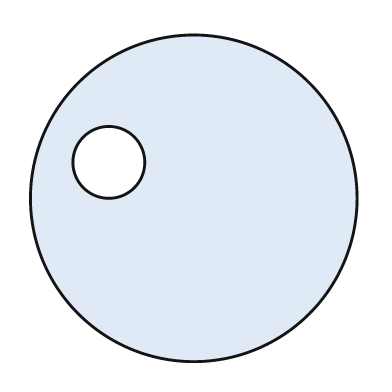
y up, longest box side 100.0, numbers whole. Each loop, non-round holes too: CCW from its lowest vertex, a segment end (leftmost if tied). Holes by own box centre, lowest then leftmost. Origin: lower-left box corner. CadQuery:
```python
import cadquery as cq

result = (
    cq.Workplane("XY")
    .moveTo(50.0, 50.0)
    .circle(50.0)
    .moveTo(24.0, 61.0)
    .circle(11.0)
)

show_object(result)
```